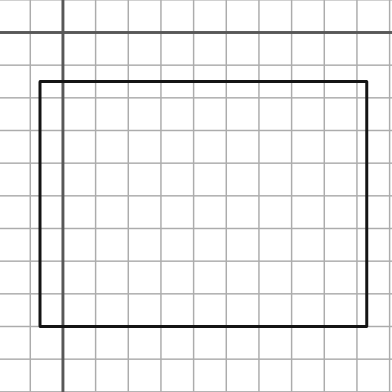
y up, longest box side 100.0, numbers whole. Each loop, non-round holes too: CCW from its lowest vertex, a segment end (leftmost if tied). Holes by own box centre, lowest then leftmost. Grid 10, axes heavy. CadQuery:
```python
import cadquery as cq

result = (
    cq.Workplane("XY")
    .moveTo(-7.0, -90.0)
    .lineTo(93.0, -90.0)
    .lineTo(93.0, -15.0)
    .lineTo(-7.0, -15.0)
    .close()
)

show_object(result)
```